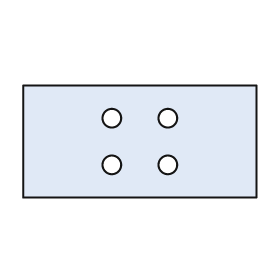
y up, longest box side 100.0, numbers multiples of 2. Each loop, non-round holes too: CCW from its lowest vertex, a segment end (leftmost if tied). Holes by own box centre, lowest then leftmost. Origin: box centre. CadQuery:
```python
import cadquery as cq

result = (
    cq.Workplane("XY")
    .moveTo(-50.0, -24.0)
    .lineTo(50.0, -24.0)
    .lineTo(50.0, 24.0)
    .lineTo(-50.0, 24.0)
    .close()
    .moveTo(-12.0, -10.0)
    .circle(4.0)
    .moveTo(12.0, -10.0)
    .circle(4.0)
    .moveTo(-12.0, 10.0)
    .circle(4.0)
    .moveTo(12.0, 10.0)
    .circle(4.0)
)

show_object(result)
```